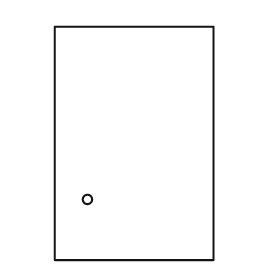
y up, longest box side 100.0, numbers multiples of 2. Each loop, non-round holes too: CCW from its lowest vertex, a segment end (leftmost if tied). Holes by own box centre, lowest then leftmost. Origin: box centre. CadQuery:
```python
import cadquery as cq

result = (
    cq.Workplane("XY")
    .moveTo(-34.0, -50.0)
    .lineTo(34.0, -50.0)
    .lineTo(34.0, 50.0)
    .lineTo(-34.0, 50.0)
    .close()
    .moveTo(-20.0, -24.0)
    .circle(2.0)
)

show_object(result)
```